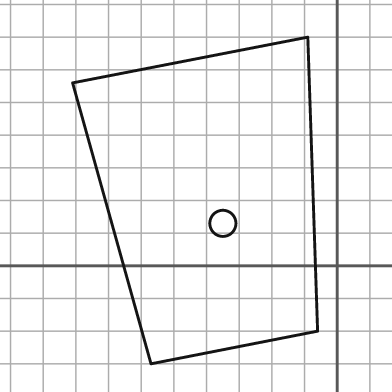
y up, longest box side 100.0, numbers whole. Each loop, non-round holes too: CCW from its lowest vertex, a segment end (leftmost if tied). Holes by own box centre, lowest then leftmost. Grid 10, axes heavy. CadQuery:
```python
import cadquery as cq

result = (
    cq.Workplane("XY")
    .moveTo(-57.0, -30.0)
    .lineTo(-6.0, -20.0)
    .lineTo(-9.0, 70.0)
    .lineTo(-81.0, 56.0)
    .close()
    .moveTo(-35.0, 13.0)
    .circle(4.0)
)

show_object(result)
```